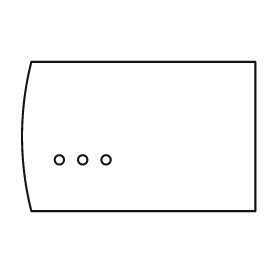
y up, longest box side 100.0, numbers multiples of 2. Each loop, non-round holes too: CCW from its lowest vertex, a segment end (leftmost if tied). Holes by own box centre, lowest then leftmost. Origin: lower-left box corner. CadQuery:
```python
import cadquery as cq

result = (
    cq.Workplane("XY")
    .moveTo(4.0, 0.0)
    .lineTo(100.0, 0.0)
    .lineTo(100.0, 64.0)
    .lineTo(4.0, 64.0)
    .threePointArc((0.0, 32.0), (4.0, 0.0))
    .close()
    .moveTo(16.0, 22.0)
    .circle(2.0)
    .moveTo(26.0, 22.0)
    .circle(2.0)
    .moveTo(36.0, 22.0)
    .circle(2.0)
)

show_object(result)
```